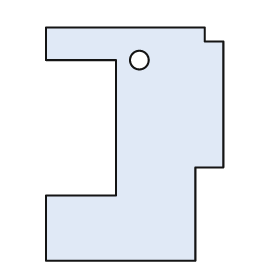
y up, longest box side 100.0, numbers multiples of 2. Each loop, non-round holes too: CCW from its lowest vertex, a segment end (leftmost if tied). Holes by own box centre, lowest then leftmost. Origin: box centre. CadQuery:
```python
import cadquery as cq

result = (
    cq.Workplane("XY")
    .moveTo(-38.0, -50.0)
    .lineTo(26.0, -50.0)
    .lineTo(26.0, -10.0)
    .lineTo(38.0, -10.0)
    .lineTo(38.0, 44.0)
    .lineTo(30.0, 44.0)
    .lineTo(30.0, 50.0)
    .lineTo(-38.0, 50.0)
    .lineTo(-38.0, 36.0)
    .lineTo(-8.0, 36.0)
    .lineTo(-8.0, -22.0)
    .lineTo(-38.0, -22.0)
    .close()
    .moveTo(2.0, 36.0)
    .circle(4.0)
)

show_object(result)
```